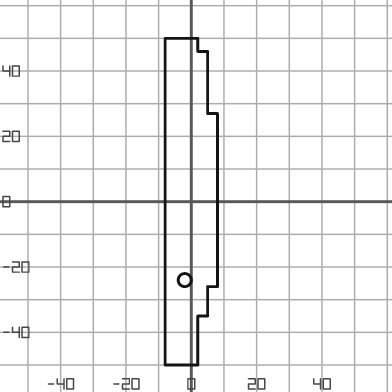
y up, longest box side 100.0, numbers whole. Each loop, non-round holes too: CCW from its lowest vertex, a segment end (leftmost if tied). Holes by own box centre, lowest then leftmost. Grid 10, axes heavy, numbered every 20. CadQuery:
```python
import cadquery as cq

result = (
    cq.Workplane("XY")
    .moveTo(-8.0, -50.0)
    .lineTo(2.0, -50.0)
    .lineTo(2.0, -35.0)
    .lineTo(5.0, -35.0)
    .lineTo(5.0, -26.0)
    .lineTo(8.0, -26.0)
    .lineTo(8.0, 27.0)
    .lineTo(5.0, 27.0)
    .lineTo(5.0, 46.0)
    .lineTo(2.0, 46.0)
    .lineTo(2.0, 50.0)
    .lineTo(-8.0, 50.0)
    .close()
    .moveTo(-2.0, -24.0)
    .circle(2.0)
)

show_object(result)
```